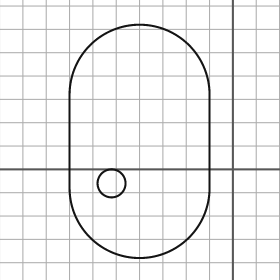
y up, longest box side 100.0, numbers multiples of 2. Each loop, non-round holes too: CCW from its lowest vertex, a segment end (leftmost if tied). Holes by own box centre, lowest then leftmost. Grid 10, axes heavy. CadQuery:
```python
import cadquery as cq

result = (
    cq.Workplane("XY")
    .moveTo(-70.0, -8.0)
    .threePointArc((-40.0, -38.0), (-10.0, -8.0))
    .lineTo(-10.0, 32.0)
    .threePointArc((-40.0, 62.0), (-70.0, 32.0))
    .close()
    .moveTo(-52.0, -6.0)
    .circle(6.0)
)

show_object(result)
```